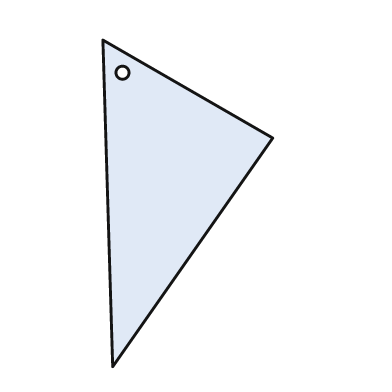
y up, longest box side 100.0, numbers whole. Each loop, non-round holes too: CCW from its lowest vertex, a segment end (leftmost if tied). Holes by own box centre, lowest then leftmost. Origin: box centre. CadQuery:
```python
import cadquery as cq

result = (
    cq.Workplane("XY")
    .moveTo(-23.0, -50.0)
    .lineTo(26.0, 20.0)
    .lineTo(-26.0, 50.0)
    .close()
    .moveTo(-20.0, 40.0)
    .circle(2.0)
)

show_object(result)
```